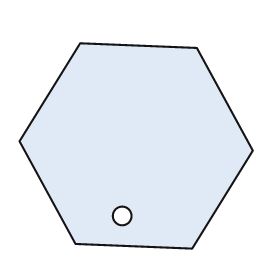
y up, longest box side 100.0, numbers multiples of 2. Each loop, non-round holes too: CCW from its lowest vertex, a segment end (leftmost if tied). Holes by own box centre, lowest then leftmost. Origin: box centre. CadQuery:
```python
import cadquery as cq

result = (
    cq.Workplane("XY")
    .moveTo(24.0, -44.0)
    .lineTo(50.0, -2.0)
    .lineTo(26.0, 42.0)
    .lineTo(-24.0, 44.0)
    .lineTo(-50.0, 2.0)
    .lineTo(-26.0, -42.0)
    .close()
    .moveTo(-6.0, -30.0)
    .circle(4.0)
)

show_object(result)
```